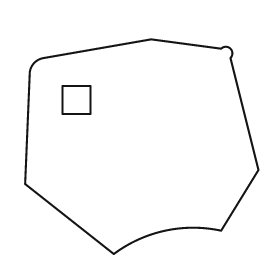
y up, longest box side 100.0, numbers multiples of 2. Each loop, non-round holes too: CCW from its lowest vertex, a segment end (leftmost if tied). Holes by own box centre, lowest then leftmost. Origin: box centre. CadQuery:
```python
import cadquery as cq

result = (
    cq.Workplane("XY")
    .moveTo(-12.0, -46.0)
    .threePointArc((10.0, -36.0), (34.0, -36.0))
    .lineTo(50.0, -10.0)
    .lineTo(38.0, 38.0)
    .threePointArc((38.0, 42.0), (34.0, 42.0))
    .lineTo(4.0, 46.0)
    .lineTo(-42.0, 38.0)
    .threePointArc((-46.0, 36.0), (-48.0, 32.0))
    .lineTo(-50.0, -16.0)
    .close()
    .moveTo(-34.0, 14.0)
    .lineTo(-22.0, 14.0)
    .lineTo(-22.0, 26.0)
    .lineTo(-34.0, 26.0)
    .close()
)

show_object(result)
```